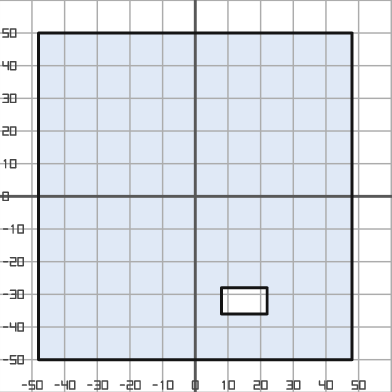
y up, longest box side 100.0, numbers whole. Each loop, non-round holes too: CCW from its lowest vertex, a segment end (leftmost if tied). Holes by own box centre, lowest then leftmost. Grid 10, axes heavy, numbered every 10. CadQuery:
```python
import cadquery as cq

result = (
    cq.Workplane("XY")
    .moveTo(-48.0, -50.0)
    .lineTo(48.0, -50.0)
    .lineTo(48.0, 50.0)
    .lineTo(-48.0, 50.0)
    .close()
    .moveTo(8.0, -36.0)
    .lineTo(22.0, -36.0)
    .lineTo(22.0, -28.0)
    .lineTo(8.0, -28.0)
    .close()
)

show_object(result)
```